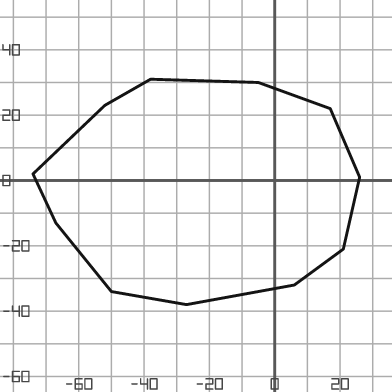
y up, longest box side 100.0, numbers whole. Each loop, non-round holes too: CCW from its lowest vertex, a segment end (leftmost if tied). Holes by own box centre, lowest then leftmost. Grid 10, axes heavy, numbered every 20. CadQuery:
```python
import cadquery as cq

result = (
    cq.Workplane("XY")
    .moveTo(-27.0, -38.0)
    .lineTo(6.0, -32.0)
    .lineTo(21.0, -21.0)
    .lineTo(26.0, 1.0)
    .lineTo(17.0, 22.0)
    .lineTo(-5.0, 30.0)
    .lineTo(-38.0, 31.0)
    .lineTo(-52.0, 23.0)
    .lineTo(-74.0, 2.0)
    .lineTo(-67.0, -13.0)
    .lineTo(-50.0, -34.0)
    .close()
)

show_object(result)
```